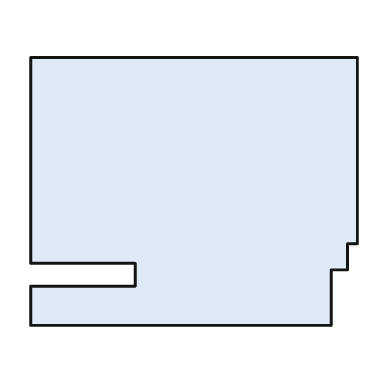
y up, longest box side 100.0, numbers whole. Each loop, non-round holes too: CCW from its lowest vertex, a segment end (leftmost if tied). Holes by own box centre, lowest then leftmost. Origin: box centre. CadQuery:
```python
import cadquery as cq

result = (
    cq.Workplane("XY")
    .moveTo(-50.0, -41.0)
    .lineTo(42.0, -41.0)
    .lineTo(42.0, -24.0)
    .lineTo(47.0, -24.0)
    .lineTo(47.0, -16.0)
    .lineTo(50.0, -16.0)
    .lineTo(50.0, 41.0)
    .lineTo(-50.0, 41.0)
    .lineTo(-50.0, -22.0)
    .lineTo(-18.0, -22.0)
    .lineTo(-18.0, -29.0)
    .lineTo(-50.0, -29.0)
    .close()
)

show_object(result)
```